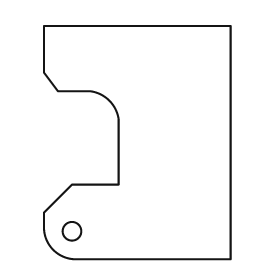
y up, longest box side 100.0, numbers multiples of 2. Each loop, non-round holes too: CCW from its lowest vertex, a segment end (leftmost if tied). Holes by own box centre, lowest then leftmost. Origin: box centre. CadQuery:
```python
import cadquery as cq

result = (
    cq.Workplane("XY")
    .moveTo(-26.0, -50.0)
    .lineTo(40.0, -50.0)
    .lineTo(40.0, 50.0)
    .lineTo(-40.0, 50.0)
    .lineTo(-40.0, 30.0)
    .lineTo(-34.0, 22.0)
    .lineTo(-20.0, 22.0)
    .threePointArc((-12.0, 18.0), (-8.0, 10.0))
    .lineTo(-8.0, -18.0)
    .lineTo(-28.0, -18.0)
    .lineTo(-40.0, -30.0)
    .lineTo(-40.0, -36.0)
    .threePointArc((-36.0, -46.0), (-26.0, -50.0))
    .close()
    .moveTo(-28.0, -38.0)
    .circle(4.0)
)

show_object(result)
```